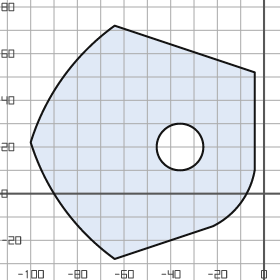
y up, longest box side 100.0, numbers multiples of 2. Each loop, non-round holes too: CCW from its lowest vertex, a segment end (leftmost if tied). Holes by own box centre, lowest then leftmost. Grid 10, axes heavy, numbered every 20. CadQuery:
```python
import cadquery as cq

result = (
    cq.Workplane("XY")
    .moveTo(-64.0, -28.0)
    .lineTo(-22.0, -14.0)
    .threePointArc((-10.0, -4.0), (-4.0, 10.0))
    .lineTo(-4.0, 52.0)
    .lineTo(-64.0, 72.0)
    .threePointArc((-86.0, 50.0), (-100.0, 22.0))
    .threePointArc((-86.0, -6.0), (-64.0, -28.0))
    .close()
    .moveTo(-36.0, 20.0)
    .circle(10.0)
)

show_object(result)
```